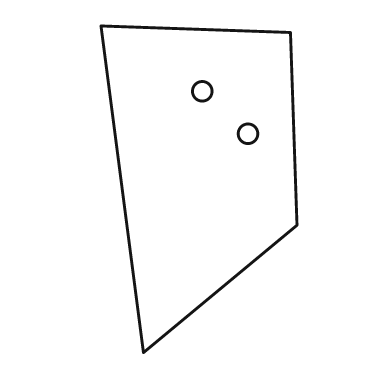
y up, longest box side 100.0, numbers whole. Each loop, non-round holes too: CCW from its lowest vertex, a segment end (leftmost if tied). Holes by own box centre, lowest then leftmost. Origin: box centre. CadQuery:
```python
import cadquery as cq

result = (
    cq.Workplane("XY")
    .moveTo(-17.0, -50.0)
    .lineTo(30.0, -11.0)
    .lineTo(28.0, 48.0)
    .lineTo(-30.0, 50.0)
    .close()
    .moveTo(15.0, 17.0)
    .circle(3.0)
    .moveTo(1.0, 30.0)
    .circle(3.0)
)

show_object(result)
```